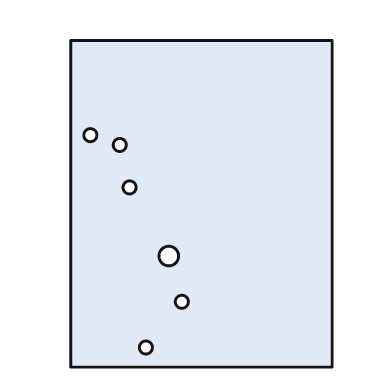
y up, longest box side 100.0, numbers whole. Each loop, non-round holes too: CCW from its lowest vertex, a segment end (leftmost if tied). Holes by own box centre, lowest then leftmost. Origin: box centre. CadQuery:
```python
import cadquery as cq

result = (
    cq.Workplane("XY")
    .moveTo(-40.0, -50.0)
    .lineTo(40.0, -50.0)
    .lineTo(40.0, 50.0)
    .lineTo(-40.0, 50.0)
    .close()
    .moveTo(-17.0, -44.0)
    .circle(2.0)
    .moveTo(-6.0, -30.0)
    .circle(2.0)
    .moveTo(-10.0, -16.0)
    .circle(3.0)
    .moveTo(-22.0, 5.0)
    .circle(2.0)
    .moveTo(-25.0, 18.0)
    .circle(2.0)
    .moveTo(-34.0, 21.0)
    .circle(2.0)
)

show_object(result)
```